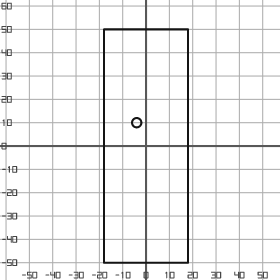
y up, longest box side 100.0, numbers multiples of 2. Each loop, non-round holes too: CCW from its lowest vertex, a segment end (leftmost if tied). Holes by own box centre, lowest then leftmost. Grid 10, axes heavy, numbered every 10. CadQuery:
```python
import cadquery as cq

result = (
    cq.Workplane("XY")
    .moveTo(-18.0, -50.0)
    .lineTo(18.0, -50.0)
    .lineTo(18.0, 50.0)
    .lineTo(-18.0, 50.0)
    .close()
    .moveTo(-4.0, 10.0)
    .circle(2.0)
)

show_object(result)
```